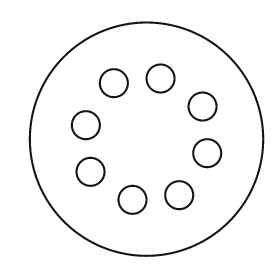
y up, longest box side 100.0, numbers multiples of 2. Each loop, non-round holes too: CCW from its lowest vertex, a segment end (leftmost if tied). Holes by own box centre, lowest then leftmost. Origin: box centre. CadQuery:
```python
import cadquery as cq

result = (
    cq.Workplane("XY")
    .moveTo(0.0, 0.0)
    .circle(50.0)
    .moveTo(-6.0, -26.0)
    .circle(6.0)
    .moveTo(14.0, -24.0)
    .circle(6.0)
    .moveTo(-24.0, -14.0)
    .circle(6.0)
    .moveTo(26.0, -6.0)
    .circle(6.0)
    .moveTo(-26.0, 6.0)
    .circle(6.0)
    .moveTo(24.0, 14.0)
    .circle(6.0)
    .moveTo(-14.0, 24.0)
    .circle(6.0)
    .moveTo(6.0, 26.0)
    .circle(6.0)
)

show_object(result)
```